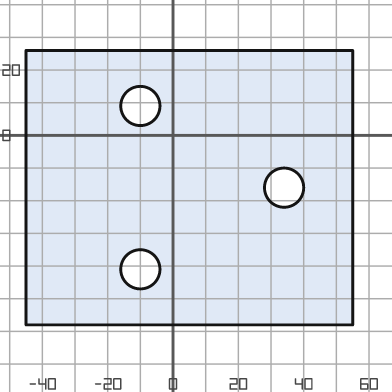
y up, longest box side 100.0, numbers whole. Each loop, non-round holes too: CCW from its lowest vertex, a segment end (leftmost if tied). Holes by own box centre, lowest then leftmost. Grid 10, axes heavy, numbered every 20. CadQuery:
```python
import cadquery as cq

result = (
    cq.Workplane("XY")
    .moveTo(-45.0, -58.0)
    .lineTo(55.0, -58.0)
    .lineTo(55.0, 26.0)
    .lineTo(-45.0, 26.0)
    .close()
    .moveTo(-10.0, -41.0)
    .circle(6.0)
    .moveTo(34.0, -16.0)
    .circle(6.0)
    .moveTo(-10.0, 9.0)
    .circle(6.0)
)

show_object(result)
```